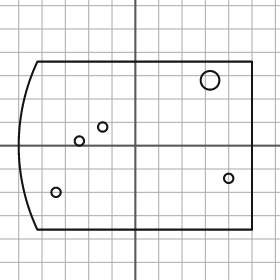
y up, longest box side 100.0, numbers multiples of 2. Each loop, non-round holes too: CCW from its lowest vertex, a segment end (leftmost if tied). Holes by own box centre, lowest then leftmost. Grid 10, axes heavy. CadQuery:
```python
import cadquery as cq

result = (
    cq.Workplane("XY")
    .moveTo(-42.0, -36.0)
    .lineTo(50.0, -36.0)
    .lineTo(50.0, 36.0)
    .lineTo(-42.0, 36.0)
    .threePointArc((-50.0, 0.0), (-42.0, -36.0))
    .close()
    .moveTo(-34.0, -20.0)
    .circle(2.0)
    .moveTo(40.0, -14.0)
    .circle(2.0)
    .moveTo(-24.0, 2.0)
    .circle(2.0)
    .moveTo(-14.0, 8.0)
    .circle(2.0)
    .moveTo(32.0, 28.0)
    .circle(4.0)
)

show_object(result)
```